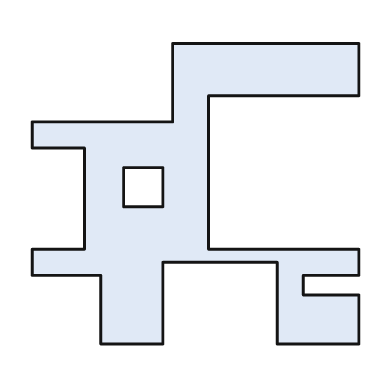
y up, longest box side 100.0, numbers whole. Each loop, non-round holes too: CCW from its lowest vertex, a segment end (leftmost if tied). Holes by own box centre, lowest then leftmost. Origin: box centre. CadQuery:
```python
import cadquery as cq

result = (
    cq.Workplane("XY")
    .moveTo(-29.0, -46.0)
    .lineTo(-10.0, -46.0)
    .lineTo(-10.0, -21.0)
    .lineTo(25.0, -21.0)
    .lineTo(25.0, -46.0)
    .lineTo(50.0, -46.0)
    .lineTo(50.0, -31.0)
    .lineTo(33.0, -31.0)
    .lineTo(33.0, -25.0)
    .lineTo(50.0, -25.0)
    .lineTo(50.0, -17.0)
    .lineTo(4.0, -17.0)
    .lineTo(4.0, 30.0)
    .lineTo(50.0, 30.0)
    .lineTo(50.0, 46.0)
    .lineTo(-7.0, 46.0)
    .lineTo(-7.0, 22.0)
    .lineTo(-50.0, 22.0)
    .lineTo(-50.0, 14.0)
    .lineTo(-34.0, 14.0)
    .lineTo(-34.0, -17.0)
    .lineTo(-50.0, -17.0)
    .lineTo(-50.0, -25.0)
    .lineTo(-29.0, -25.0)
    .close()
    .moveTo(-22.0, -4.0)
    .lineTo(-10.0, -4.0)
    .lineTo(-10.0, 8.0)
    .lineTo(-22.0, 8.0)
    .close()
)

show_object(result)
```